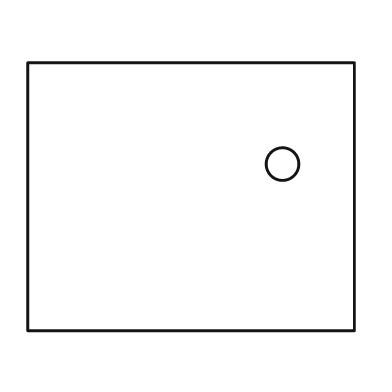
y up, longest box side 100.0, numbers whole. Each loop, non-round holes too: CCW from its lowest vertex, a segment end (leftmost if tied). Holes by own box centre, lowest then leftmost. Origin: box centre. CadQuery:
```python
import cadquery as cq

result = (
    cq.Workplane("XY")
    .moveTo(-50.0, -41.0)
    .lineTo(50.0, -41.0)
    .lineTo(50.0, 41.0)
    .lineTo(-50.0, 41.0)
    .close()
    .moveTo(28.0, 10.0)
    .circle(5.0)
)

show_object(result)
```